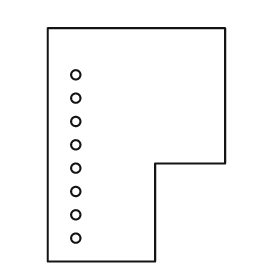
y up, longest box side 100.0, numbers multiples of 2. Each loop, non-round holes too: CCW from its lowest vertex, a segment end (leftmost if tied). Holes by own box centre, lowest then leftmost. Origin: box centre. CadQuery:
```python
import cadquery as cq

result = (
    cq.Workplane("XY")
    .moveTo(-38.0, -50.0)
    .lineTo(8.0, -50.0)
    .lineTo(8.0, -8.0)
    .lineTo(38.0, -8.0)
    .lineTo(38.0, 50.0)
    .lineTo(-38.0, 50.0)
    .close()
    .moveTo(-26.0, -40.0)
    .circle(2.0)
    .moveTo(-26.0, -30.0)
    .circle(2.0)
    .moveTo(-26.0, -20.0)
    .circle(2.0)
    .moveTo(-26.0, -10.0)
    .circle(2.0)
    .moveTo(-26.0, 0.0)
    .circle(2.0)
    .moveTo(-26.0, 10.0)
    .circle(2.0)
    .moveTo(-26.0, 20.0)
    .circle(2.0)
    .moveTo(-26.0, 30.0)
    .circle(2.0)
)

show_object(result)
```